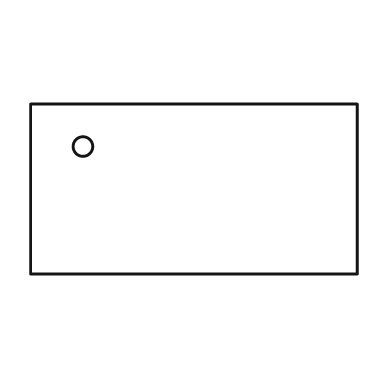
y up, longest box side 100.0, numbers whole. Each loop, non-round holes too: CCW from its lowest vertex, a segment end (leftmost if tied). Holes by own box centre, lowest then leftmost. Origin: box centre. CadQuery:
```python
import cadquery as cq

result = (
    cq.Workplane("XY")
    .moveTo(-50.0, -26.0)
    .lineTo(50.0, -26.0)
    .lineTo(50.0, 26.0)
    .lineTo(-50.0, 26.0)
    .close()
    .moveTo(-34.0, 13.0)
    .circle(3.0)
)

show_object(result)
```